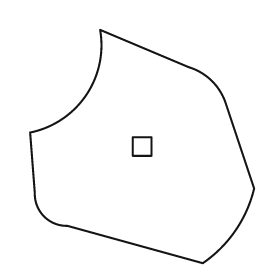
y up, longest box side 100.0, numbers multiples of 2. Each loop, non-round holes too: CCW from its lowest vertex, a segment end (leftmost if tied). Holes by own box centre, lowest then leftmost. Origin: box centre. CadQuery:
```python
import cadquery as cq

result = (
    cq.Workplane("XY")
    .moveTo(26.0, -50.0)
    .threePointArc((40.0, -36.0), (48.0, -18.0))
    .lineTo(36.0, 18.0)
    .threePointArc((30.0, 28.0), (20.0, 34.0))
    .lineTo(-18.0, 50.0)
    .threePointArc((-24.0, 22.0), (-48.0, 6.0))
    .lineTo(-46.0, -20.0)
    .threePointArc((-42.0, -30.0), (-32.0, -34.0))
    .close()
    .moveTo(-4.0, -4.0)
    .lineTo(4.0, -4.0)
    .lineTo(4.0, 4.0)
    .lineTo(-4.0, 4.0)
    .close()
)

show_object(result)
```